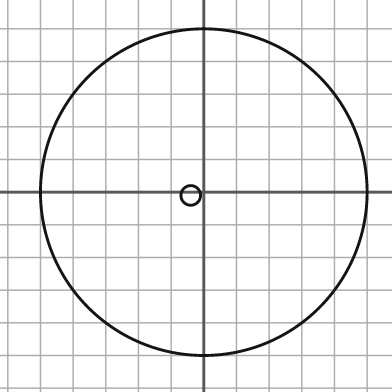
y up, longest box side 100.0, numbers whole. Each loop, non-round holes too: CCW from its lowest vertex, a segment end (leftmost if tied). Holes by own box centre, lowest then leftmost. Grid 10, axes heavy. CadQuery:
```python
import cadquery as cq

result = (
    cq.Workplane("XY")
    .moveTo(0.0, 0.0)
    .circle(50.0)
    .moveTo(-4.0, -1.0)
    .circle(3.0)
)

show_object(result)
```